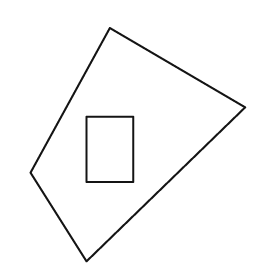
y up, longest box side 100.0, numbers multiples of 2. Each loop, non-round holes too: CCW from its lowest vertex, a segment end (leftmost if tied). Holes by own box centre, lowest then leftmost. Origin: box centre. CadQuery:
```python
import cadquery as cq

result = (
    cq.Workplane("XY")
    .moveTo(-22.0, -50.0)
    .lineTo(46.0, 16.0)
    .lineTo(-12.0, 50.0)
    .lineTo(-46.0, -12.0)
    .close()
    .moveTo(-22.0, -16.0)
    .lineTo(-2.0, -16.0)
    .lineTo(-2.0, 12.0)
    .lineTo(-22.0, 12.0)
    .close()
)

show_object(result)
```